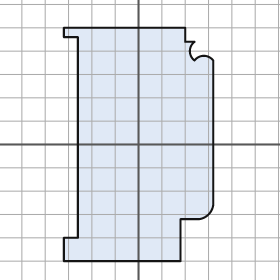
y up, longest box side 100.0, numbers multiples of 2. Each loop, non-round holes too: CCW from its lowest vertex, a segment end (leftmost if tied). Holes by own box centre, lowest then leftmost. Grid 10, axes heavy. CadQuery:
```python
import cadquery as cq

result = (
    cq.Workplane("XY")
    .moveTo(-32.0, -50.0)
    .lineTo(18.0, -50.0)
    .lineTo(18.0, -32.0)
    .lineTo(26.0, -32.0)
    .threePointArc((30.0, -30.0), (32.0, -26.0))
    .lineTo(32.0, 36.0)
    .threePointArc((28.0, 38.0), (24.0, 36.0))
    .threePointArc((22.0, 40.0), (24.0, 44.0))
    .lineTo(20.0, 44.0)
    .lineTo(20.0, 50.0)
    .lineTo(-32.0, 50.0)
    .lineTo(-32.0, 46.0)
    .lineTo(-26.0, 46.0)
    .lineTo(-26.0, -40.0)
    .lineTo(-32.0, -40.0)
    .close()
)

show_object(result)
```